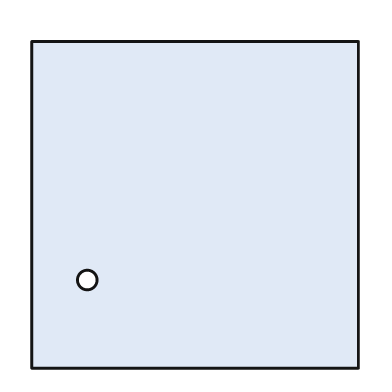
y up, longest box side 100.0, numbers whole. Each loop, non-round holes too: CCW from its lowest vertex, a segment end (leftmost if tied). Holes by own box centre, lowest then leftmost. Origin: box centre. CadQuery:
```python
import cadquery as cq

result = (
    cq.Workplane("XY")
    .moveTo(-50.0, -50.0)
    .lineTo(50.0, -50.0)
    .lineTo(50.0, 50.0)
    .lineTo(-50.0, 50.0)
    .close()
    .moveTo(-33.0, -23.0)
    .circle(3.0)
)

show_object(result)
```